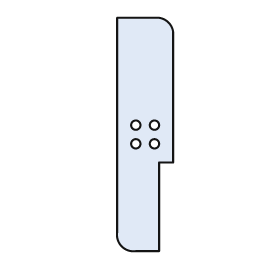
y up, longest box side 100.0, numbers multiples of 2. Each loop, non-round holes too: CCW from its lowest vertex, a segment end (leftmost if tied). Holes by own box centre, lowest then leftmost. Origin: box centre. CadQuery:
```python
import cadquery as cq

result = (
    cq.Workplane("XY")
    .moveTo(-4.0, -50.0)
    .lineTo(6.0, -50.0)
    .lineTo(6.0, -12.0)
    .lineTo(12.0, -12.0)
    .lineTo(12.0, 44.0)
    .threePointArc((10.0, 48.0), (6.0, 50.0))
    .lineTo(-12.0, 50.0)
    .lineTo(-12.0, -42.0)
    .threePointArc((-10.0, -48.0), (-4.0, -50.0))
    .close()
    .moveTo(-4.0, -4.0)
    .circle(2.0)
    .moveTo(4.0, -4.0)
    .circle(2.0)
    .moveTo(-4.0, 4.0)
    .circle(2.0)
    .moveTo(4.0, 4.0)
    .circle(2.0)
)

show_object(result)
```